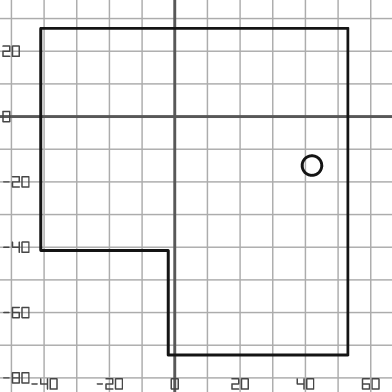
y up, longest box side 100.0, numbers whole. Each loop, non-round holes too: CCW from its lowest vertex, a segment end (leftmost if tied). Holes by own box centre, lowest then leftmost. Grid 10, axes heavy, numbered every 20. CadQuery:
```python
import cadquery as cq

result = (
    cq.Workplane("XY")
    .moveTo(-2.0, -73.0)
    .lineTo(53.0, -73.0)
    .lineTo(53.0, 27.0)
    .lineTo(-41.0, 27.0)
    .lineTo(-41.0, -41.0)
    .lineTo(-2.0, -41.0)
    .close()
    .moveTo(42.0, -15.0)
    .circle(3.0)
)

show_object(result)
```